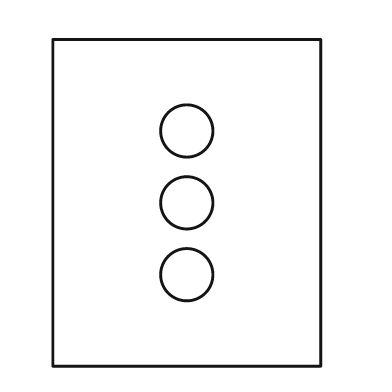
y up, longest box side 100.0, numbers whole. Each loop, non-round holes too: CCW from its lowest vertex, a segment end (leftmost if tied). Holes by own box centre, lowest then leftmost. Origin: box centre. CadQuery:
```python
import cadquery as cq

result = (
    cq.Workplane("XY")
    .moveTo(-41.0, -50.0)
    .lineTo(41.0, -50.0)
    .lineTo(41.0, 50.0)
    .lineTo(-41.0, 50.0)
    .close()
    .moveTo(0.0, -22.0)
    .circle(8.0)
    .moveTo(0.0, 0.0)
    .circle(8.0)
    .moveTo(0.0, 22.0)
    .circle(8.0)
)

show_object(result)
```